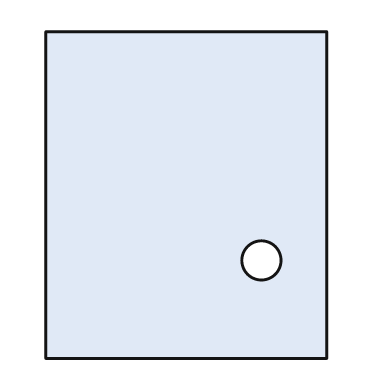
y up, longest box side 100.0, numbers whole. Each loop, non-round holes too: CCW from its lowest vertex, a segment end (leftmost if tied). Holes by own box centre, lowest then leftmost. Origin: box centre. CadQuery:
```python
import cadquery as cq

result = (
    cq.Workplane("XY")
    .moveTo(-43.0, -50.0)
    .lineTo(43.0, -50.0)
    .lineTo(43.0, 50.0)
    .lineTo(-43.0, 50.0)
    .close()
    .moveTo(23.0, -20.0)
    .circle(6.0)
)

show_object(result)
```